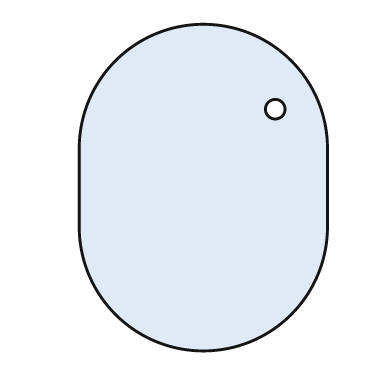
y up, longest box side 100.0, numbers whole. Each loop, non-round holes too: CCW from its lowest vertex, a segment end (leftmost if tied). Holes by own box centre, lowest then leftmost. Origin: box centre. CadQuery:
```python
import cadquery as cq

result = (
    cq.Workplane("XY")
    .moveTo(-38.0, -12.0)
    .threePointArc((0.0, -50.0), (38.0, -12.0))
    .lineTo(38.0, 12.0)
    .threePointArc((0.0, 50.0), (-38.0, 12.0))
    .close()
    .moveTo(22.0, 24.0)
    .circle(3.0)
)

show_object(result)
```